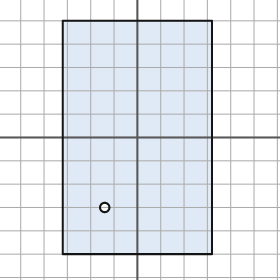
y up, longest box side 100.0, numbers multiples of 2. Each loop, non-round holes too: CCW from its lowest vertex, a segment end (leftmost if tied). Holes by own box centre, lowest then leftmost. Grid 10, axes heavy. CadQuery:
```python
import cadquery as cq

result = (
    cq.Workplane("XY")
    .moveTo(-32.0, -50.0)
    .lineTo(32.0, -50.0)
    .lineTo(32.0, 50.0)
    .lineTo(-32.0, 50.0)
    .close()
    .moveTo(-14.0, -30.0)
    .circle(2.0)
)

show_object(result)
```